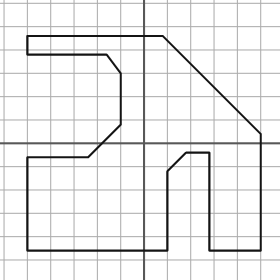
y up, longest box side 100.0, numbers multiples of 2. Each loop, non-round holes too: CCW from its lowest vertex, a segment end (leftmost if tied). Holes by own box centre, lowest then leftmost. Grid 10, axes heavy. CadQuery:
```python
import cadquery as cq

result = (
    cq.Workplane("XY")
    .moveTo(-50.0, -46.0)
    .lineTo(10.0, -46.0)
    .lineTo(10.0, -12.0)
    .lineTo(18.0, -4.0)
    .lineTo(28.0, -4.0)
    .lineTo(28.0, -46.0)
    .lineTo(50.0, -46.0)
    .lineTo(50.0, 4.0)
    .lineTo(8.0, 46.0)
    .lineTo(-50.0, 46.0)
    .lineTo(-50.0, 38.0)
    .lineTo(-16.0, 38.0)
    .lineTo(-10.0, 30.0)
    .lineTo(-10.0, 8.0)
    .lineTo(-24.0, -6.0)
    .lineTo(-50.0, -6.0)
    .close()
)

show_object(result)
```